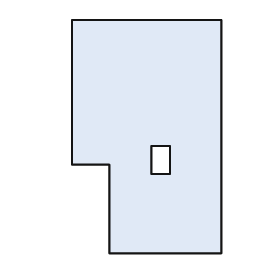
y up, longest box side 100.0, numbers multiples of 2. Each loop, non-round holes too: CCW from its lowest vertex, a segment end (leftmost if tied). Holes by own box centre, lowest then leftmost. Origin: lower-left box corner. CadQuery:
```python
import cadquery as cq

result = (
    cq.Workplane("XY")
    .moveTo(16.0, 0.0)
    .lineTo(64.0, 0.0)
    .lineTo(64.0, 100.0)
    .lineTo(0.0, 100.0)
    .lineTo(0.0, 38.0)
    .lineTo(16.0, 38.0)
    .close()
    .moveTo(34.0, 34.0)
    .lineTo(42.0, 34.0)
    .lineTo(42.0, 46.0)
    .lineTo(34.0, 46.0)
    .close()
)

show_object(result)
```